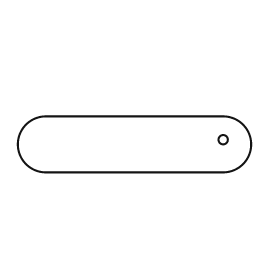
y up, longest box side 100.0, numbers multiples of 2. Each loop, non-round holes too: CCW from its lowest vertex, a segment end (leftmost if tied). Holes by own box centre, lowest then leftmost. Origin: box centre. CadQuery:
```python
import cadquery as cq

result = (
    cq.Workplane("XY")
    .moveTo(-38.0, -12.0)
    .lineTo(38.0, -12.0)
    .threePointArc((50.0, 0.0), (38.0, 12.0))
    .lineTo(-38.0, 12.0)
    .threePointArc((-50.0, 0.0), (-38.0, -12.0))
    .close()
    .moveTo(38.0, 2.0)
    .circle(2.0)
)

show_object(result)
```